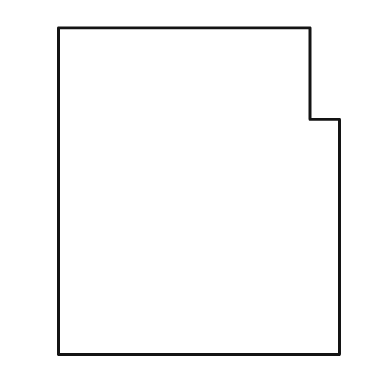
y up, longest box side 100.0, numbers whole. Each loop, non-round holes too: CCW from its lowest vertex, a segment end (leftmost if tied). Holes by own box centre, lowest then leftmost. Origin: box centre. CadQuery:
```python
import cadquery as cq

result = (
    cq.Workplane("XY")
    .moveTo(-43.0, -50.0)
    .lineTo(43.0, -50.0)
    .lineTo(43.0, 22.0)
    .lineTo(34.0, 22.0)
    .lineTo(34.0, 50.0)
    .lineTo(-43.0, 50.0)
    .close()
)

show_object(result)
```